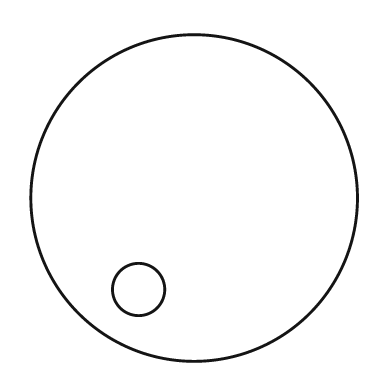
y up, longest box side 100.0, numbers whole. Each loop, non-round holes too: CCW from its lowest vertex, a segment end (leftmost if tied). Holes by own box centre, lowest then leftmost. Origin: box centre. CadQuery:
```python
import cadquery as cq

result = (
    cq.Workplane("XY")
    .moveTo(0.0, 0.0)
    .circle(50.0)
    .moveTo(-17.0, -28.0)
    .circle(8.0)
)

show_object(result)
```